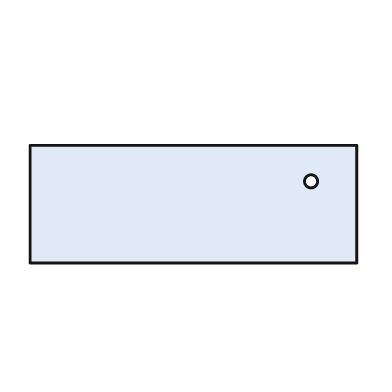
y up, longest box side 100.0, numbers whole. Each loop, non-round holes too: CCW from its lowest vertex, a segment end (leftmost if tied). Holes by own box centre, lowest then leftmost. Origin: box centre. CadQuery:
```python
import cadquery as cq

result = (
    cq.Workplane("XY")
    .moveTo(-50.0, -18.0)
    .lineTo(50.0, -18.0)
    .lineTo(50.0, 18.0)
    .lineTo(-50.0, 18.0)
    .close()
    .moveTo(36.0, 7.0)
    .circle(2.0)
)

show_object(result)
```